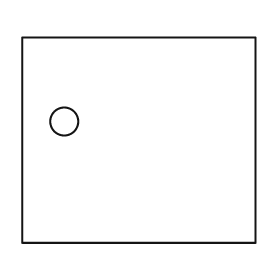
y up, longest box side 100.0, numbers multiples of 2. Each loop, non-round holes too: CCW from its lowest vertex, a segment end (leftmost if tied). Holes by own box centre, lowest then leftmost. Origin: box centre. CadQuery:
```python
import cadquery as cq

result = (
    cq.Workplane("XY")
    .moveTo(-50.0, -44.0)
    .lineTo(50.0, -44.0)
    .lineTo(50.0, 44.0)
    .lineTo(-50.0, 44.0)
    .close()
    .moveTo(-32.0, 8.0)
    .circle(6.0)
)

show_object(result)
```